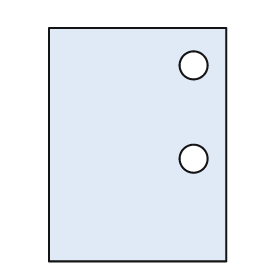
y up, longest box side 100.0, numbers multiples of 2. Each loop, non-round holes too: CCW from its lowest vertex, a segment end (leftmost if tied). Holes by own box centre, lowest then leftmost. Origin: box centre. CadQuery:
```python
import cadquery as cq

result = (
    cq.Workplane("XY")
    .moveTo(-38.0, -50.0)
    .lineTo(38.0, -50.0)
    .lineTo(38.0, 50.0)
    .lineTo(-38.0, 50.0)
    .close()
    .moveTo(24.0, -6.0)
    .circle(6.0)
    .moveTo(24.0, 34.0)
    .circle(6.0)
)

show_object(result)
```